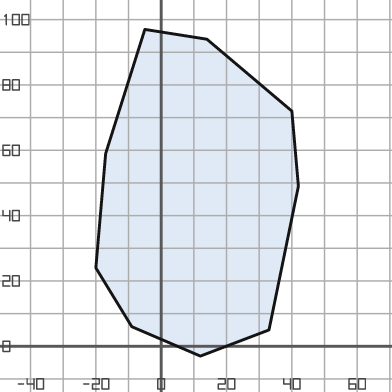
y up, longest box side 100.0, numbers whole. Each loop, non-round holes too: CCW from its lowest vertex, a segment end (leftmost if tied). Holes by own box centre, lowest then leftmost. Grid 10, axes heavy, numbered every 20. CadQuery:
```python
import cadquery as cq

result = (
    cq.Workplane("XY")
    .moveTo(12.0, -3.0)
    .lineTo(33.0, 5.0)
    .lineTo(42.0, 49.0)
    .lineTo(40.0, 72.0)
    .lineTo(14.0, 94.0)
    .lineTo(-5.0, 97.0)
    .lineTo(-17.0, 59.0)
    .lineTo(-20.0, 24.0)
    .lineTo(-9.0, 6.0)
    .close()
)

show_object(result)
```